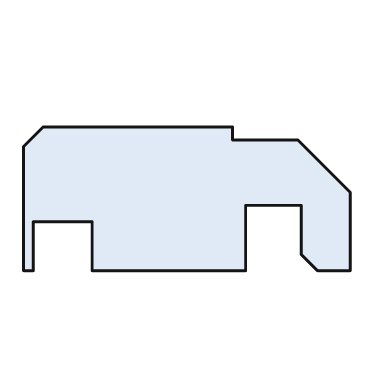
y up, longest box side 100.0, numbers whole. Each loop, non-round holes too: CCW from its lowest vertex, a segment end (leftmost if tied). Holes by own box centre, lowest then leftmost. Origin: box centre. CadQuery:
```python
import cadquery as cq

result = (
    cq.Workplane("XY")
    .moveTo(-50.0, -22.0)
    .lineTo(-47.0, -22.0)
    .lineTo(-47.0, -7.0)
    .lineTo(-29.0, -7.0)
    .lineTo(-29.0, -22.0)
    .lineTo(18.0, -22.0)
    .lineTo(18.0, -2.0)
    .lineTo(35.0, -2.0)
    .lineTo(35.0, -17.0)
    .lineTo(40.0, -22.0)
    .lineTo(50.0, -22.0)
    .lineTo(50.0, 2.0)
    .lineTo(34.0, 18.0)
    .lineTo(14.0, 18.0)
    .lineTo(14.0, 22.0)
    .lineTo(-44.0, 22.0)
    .lineTo(-50.0, 16.0)
    .close()
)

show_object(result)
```